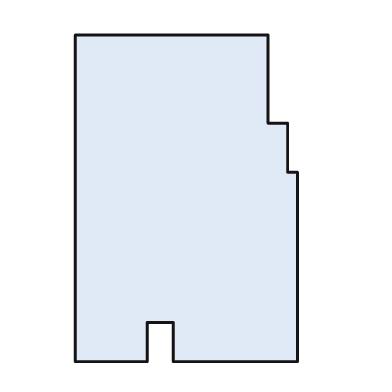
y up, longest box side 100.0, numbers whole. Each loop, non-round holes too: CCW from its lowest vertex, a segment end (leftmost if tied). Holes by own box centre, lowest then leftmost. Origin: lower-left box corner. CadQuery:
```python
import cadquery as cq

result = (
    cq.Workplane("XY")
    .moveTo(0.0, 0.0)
    .lineTo(22.0, 0.0)
    .lineTo(22.0, 12.0)
    .lineTo(30.0, 12.0)
    .lineTo(30.0, 0.0)
    .lineTo(68.0, 0.0)
    .lineTo(68.0, 58.0)
    .lineTo(65.0, 58.0)
    .lineTo(65.0, 73.0)
    .lineTo(59.0, 73.0)
    .lineTo(59.0, 100.0)
    .lineTo(0.0, 100.0)
    .close()
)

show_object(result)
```